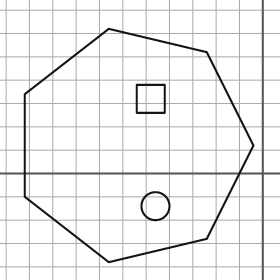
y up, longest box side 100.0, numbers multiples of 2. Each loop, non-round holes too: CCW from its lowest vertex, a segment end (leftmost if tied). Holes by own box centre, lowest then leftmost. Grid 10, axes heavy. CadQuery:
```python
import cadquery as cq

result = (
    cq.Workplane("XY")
    .moveTo(-66.0, -38.0)
    .lineTo(-24.0, -28.0)
    .lineTo(-4.0, 12.0)
    .lineTo(-24.0, 52.0)
    .lineTo(-66.0, 62.0)
    .lineTo(-102.0, 34.0)
    .lineTo(-102.0, -10.0)
    .close()
    .moveTo(-46.0, -14.0)
    .circle(6.0)
    .moveTo(-54.0, 26.0)
    .lineTo(-42.0, 26.0)
    .lineTo(-42.0, 38.0)
    .lineTo(-54.0, 38.0)
    .close()
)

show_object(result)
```